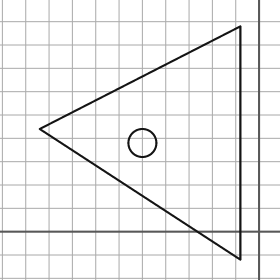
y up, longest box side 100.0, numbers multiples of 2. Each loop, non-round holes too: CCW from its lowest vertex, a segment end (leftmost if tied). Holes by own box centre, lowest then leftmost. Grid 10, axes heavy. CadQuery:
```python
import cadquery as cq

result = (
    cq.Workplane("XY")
    .moveTo(-8.0, -12.0)
    .lineTo(-8.0, 88.0)
    .lineTo(-94.0, 44.0)
    .close()
    .moveTo(-50.0, 38.0)
    .circle(6.0)
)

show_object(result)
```